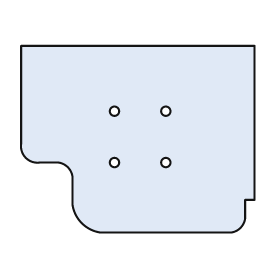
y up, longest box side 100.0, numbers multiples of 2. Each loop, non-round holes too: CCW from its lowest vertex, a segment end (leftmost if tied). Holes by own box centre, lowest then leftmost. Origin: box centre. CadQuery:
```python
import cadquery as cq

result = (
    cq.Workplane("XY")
    .moveTo(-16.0, -40.0)
    .lineTo(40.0, -40.0)
    .threePointArc((44.0, -38.0), (46.0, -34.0))
    .lineTo(46.0, -26.0)
    .lineTo(50.0, -26.0)
    .lineTo(50.0, 40.0)
    .lineTo(-50.0, 40.0)
    .lineTo(-50.0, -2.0)
    .threePointArc((-48.0, -8.0), (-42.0, -10.0))
    .lineTo(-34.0, -10.0)
    .threePointArc((-30.0, -12.0), (-28.0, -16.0))
    .lineTo(-28.0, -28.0)
    .threePointArc((-24.0, -36.0), (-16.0, -40.0))
    .close()
    .moveTo(-10.0, -10.0)
    .circle(2.0)
    .moveTo(12.0, -10.0)
    .circle(2.0)
    .moveTo(-10.0, 12.0)
    .circle(2.0)
    .moveTo(12.0, 12.0)
    .circle(2.0)
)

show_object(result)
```